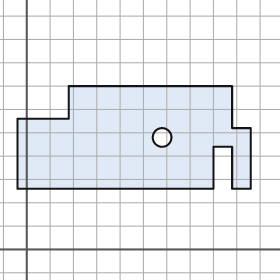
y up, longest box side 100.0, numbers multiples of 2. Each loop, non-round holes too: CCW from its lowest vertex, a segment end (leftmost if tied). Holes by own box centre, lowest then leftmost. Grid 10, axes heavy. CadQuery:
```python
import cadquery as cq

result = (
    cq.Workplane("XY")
    .moveTo(-4.0, 26.0)
    .lineTo(80.0, 26.0)
    .lineTo(80.0, 44.0)
    .lineTo(88.0, 44.0)
    .lineTo(88.0, 26.0)
    .lineTo(96.0, 26.0)
    .lineTo(96.0, 52.0)
    .lineTo(88.0, 52.0)
    .lineTo(88.0, 70.0)
    .lineTo(18.0, 70.0)
    .lineTo(18.0, 56.0)
    .lineTo(-4.0, 56.0)
    .close()
    .moveTo(58.0, 48.0)
    .circle(4.0)
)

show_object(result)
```